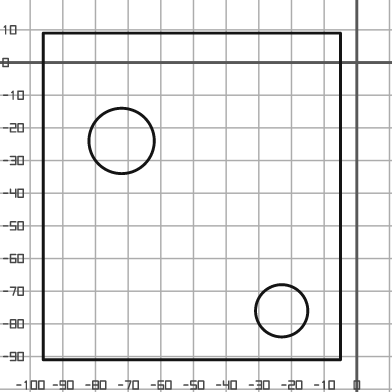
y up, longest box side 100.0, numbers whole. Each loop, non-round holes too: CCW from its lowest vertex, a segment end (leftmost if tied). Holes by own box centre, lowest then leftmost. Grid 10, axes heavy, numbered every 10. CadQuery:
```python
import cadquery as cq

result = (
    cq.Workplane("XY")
    .moveTo(-96.0, -91.0)
    .lineTo(-5.0, -91.0)
    .lineTo(-5.0, 9.0)
    .lineTo(-96.0, 9.0)
    .close()
    .moveTo(-23.0, -76.0)
    .circle(8.0)
    .moveTo(-72.0, -24.0)
    .circle(10.0)
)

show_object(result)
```